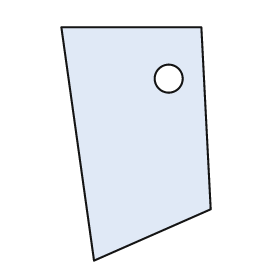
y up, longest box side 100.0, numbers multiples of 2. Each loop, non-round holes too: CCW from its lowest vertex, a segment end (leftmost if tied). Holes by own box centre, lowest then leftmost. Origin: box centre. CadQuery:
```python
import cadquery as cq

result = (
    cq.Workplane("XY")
    .moveTo(-18.0, -50.0)
    .lineTo(32.0, -28.0)
    .lineTo(28.0, 50.0)
    .lineTo(-32.0, 50.0)
    .close()
    .moveTo(14.0, 28.0)
    .circle(6.0)
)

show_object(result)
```